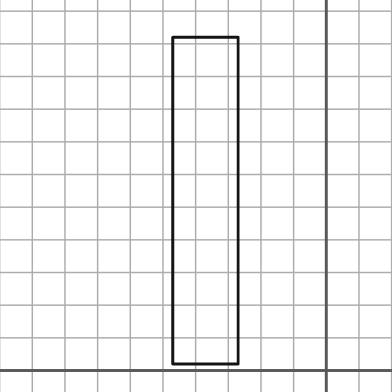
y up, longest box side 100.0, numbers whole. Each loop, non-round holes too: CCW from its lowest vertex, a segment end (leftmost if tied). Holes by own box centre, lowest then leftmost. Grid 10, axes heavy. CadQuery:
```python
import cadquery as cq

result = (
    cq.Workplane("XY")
    .moveTo(-47.0, 2.0)
    .lineTo(-27.0, 2.0)
    .lineTo(-27.0, 102.0)
    .lineTo(-47.0, 102.0)
    .close()
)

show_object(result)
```